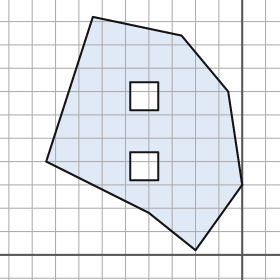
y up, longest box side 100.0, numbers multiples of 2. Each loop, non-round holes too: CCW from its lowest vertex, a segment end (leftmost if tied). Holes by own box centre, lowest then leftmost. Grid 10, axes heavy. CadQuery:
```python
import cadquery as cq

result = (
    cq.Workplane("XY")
    .moveTo(-20.0, 2.0)
    .lineTo(0.0, 30.0)
    .lineTo(-6.0, 70.0)
    .lineTo(-26.0, 94.0)
    .lineTo(-64.0, 102.0)
    .lineTo(-84.0, 40.0)
    .lineTo(-40.0, 18.0)
    .close()
    .moveTo(-48.0, 32.0)
    .lineTo(-36.0, 32.0)
    .lineTo(-36.0, 44.0)
    .lineTo(-48.0, 44.0)
    .close()
    .moveTo(-48.0, 62.0)
    .lineTo(-36.0, 62.0)
    .lineTo(-36.0, 74.0)
    .lineTo(-48.0, 74.0)
    .close()
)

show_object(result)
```